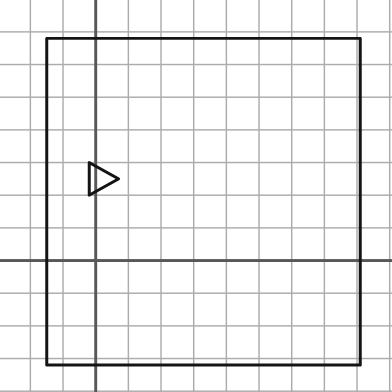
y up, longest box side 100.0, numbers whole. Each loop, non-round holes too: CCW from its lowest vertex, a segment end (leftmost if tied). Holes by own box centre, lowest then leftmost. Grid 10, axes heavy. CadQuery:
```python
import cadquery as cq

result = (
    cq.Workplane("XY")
    .moveTo(-15.0, -32.0)
    .lineTo(81.0, -32.0)
    .lineTo(81.0, 68.0)
    .lineTo(-15.0, 68.0)
    .close()
    .moveTo(-2.0, 20.0)
    .lineTo(7.0, 25.0)
    .lineTo(-2.0, 30.0)
    .close()
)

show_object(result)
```